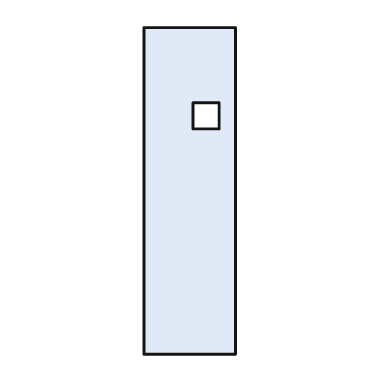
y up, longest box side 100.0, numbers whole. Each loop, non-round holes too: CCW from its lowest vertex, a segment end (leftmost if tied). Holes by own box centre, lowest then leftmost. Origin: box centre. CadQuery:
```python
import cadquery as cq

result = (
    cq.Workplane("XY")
    .moveTo(-14.0, -50.0)
    .lineTo(14.0, -50.0)
    .lineTo(14.0, 50.0)
    .lineTo(-14.0, 50.0)
    .close()
    .moveTo(1.0, 19.0)
    .lineTo(9.0, 19.0)
    .lineTo(9.0, 27.0)
    .lineTo(1.0, 27.0)
    .close()
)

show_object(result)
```